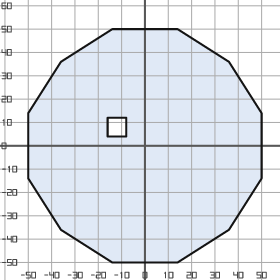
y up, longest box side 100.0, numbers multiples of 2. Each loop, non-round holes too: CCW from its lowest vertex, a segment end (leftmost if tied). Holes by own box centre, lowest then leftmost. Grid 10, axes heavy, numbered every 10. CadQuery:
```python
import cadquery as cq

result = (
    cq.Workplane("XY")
    .moveTo(-14.0, -50.0)
    .lineTo(14.0, -50.0)
    .lineTo(36.0, -36.0)
    .lineTo(50.0, -14.0)
    .lineTo(50.0, 14.0)
    .lineTo(36.0, 36.0)
    .lineTo(14.0, 50.0)
    .lineTo(-14.0, 50.0)
    .lineTo(-36.0, 36.0)
    .lineTo(-50.0, 14.0)
    .lineTo(-50.0, -14.0)
    .lineTo(-36.0, -36.0)
    .close()
    .moveTo(-16.0, 4.0)
    .lineTo(-8.0, 4.0)
    .lineTo(-8.0, 12.0)
    .lineTo(-16.0, 12.0)
    .close()
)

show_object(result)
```